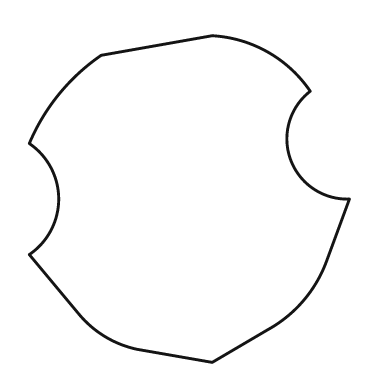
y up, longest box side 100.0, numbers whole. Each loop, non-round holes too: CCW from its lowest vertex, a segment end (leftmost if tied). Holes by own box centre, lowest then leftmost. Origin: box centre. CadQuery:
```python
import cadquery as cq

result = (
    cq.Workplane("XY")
    .moveTo(7.0, -50.0)
    .lineTo(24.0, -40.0)
    .threePointArc((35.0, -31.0), (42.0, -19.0))
    .lineTo(49.0, 0.0)
    .threePointArc((31.0, 12.0), (37.0, 33.0))
    .threePointArc((24.0, 45.0), (7.0, 50.0))
    .lineTo(-27.0, 44.0)
    .threePointArc((-40.0, 32.0), (-49.0, 17.0))
    .threePointArc((-40.0, 0.0), (-49.0, -17.0))
    .lineTo(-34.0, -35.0)
    .threePointArc((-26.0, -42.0), (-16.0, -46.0))
    .close()
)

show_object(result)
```